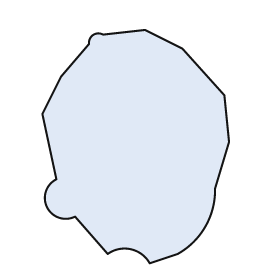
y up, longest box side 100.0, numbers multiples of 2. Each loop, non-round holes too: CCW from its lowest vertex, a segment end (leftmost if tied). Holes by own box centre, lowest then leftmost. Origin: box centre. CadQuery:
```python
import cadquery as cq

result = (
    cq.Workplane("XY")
    .moveTo(6.0, -50.0)
    .lineTo(18.0, -46.0)
    .threePointArc((30.0, -34.0), (34.0, -18.0))
    .lineTo(40.0, 2.0)
    .lineTo(38.0, 22.0)
    .lineTo(20.0, 42.0)
    .lineTo(4.0, 50.0)
    .lineTo(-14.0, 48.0)
    .threePointArc((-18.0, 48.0), (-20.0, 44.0))
    .lineTo(-32.0, 30.0)
    .lineTo(-40.0, 14.0)
    .lineTo(-34.0, -14.0)
    .threePointArc((-38.0, -26.0), (-26.0, -30.0))
    .lineTo(-12.0, -46.0)
    .threePointArc((-2.0, -44.0), (6.0, -50.0))
    .close()
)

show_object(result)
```